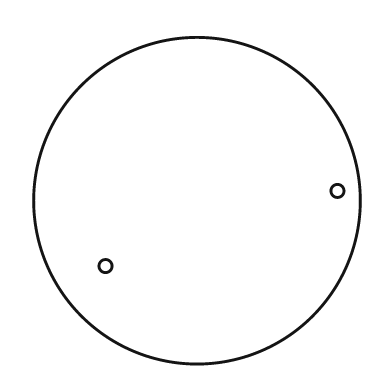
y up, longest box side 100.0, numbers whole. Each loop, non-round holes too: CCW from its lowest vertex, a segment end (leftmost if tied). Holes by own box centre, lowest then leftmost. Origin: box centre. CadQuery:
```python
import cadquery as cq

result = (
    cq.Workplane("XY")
    .moveTo(0.0, 0.0)
    .circle(50.0)
    .moveTo(-28.0, -20.0)
    .circle(2.0)
    .moveTo(43.0, 3.0)
    .circle(2.0)
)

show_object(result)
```